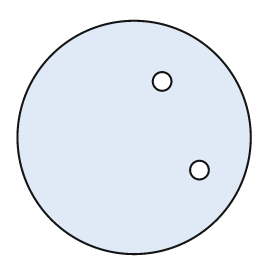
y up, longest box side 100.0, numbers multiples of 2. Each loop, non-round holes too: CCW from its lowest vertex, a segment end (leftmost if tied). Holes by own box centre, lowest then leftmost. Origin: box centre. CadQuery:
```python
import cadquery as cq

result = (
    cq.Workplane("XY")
    .moveTo(0.0, 0.0)
    .circle(50.0)
    .moveTo(28.0, -14.0)
    .circle(4.0)
    .moveTo(12.0, 24.0)
    .circle(4.0)
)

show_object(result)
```